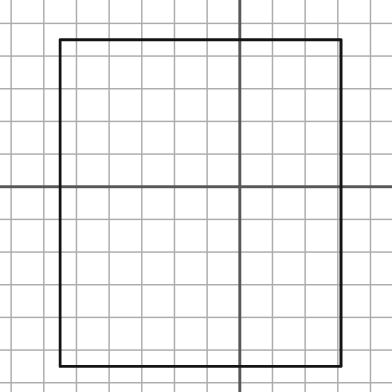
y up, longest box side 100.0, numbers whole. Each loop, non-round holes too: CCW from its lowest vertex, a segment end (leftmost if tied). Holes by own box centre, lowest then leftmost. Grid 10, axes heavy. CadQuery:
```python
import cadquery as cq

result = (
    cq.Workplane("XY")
    .moveTo(-55.0, -55.0)
    .lineTo(31.0, -55.0)
    .lineTo(31.0, 45.0)
    .lineTo(-55.0, 45.0)
    .close()
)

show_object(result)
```